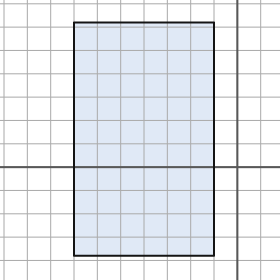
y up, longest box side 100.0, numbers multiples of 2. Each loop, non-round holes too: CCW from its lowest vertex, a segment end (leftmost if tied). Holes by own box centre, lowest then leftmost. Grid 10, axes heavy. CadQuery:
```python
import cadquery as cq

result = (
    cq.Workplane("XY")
    .moveTo(-70.0, -38.0)
    .lineTo(-10.0, -38.0)
    .lineTo(-10.0, 62.0)
    .lineTo(-70.0, 62.0)
    .close()
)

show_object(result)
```